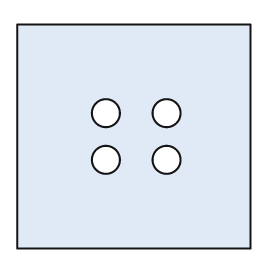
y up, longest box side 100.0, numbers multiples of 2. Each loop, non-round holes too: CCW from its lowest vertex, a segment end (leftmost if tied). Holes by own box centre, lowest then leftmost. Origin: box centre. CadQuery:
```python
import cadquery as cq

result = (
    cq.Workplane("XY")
    .moveTo(-50.0, -48.0)
    .lineTo(50.0, -48.0)
    .lineTo(50.0, 48.0)
    .lineTo(-50.0, 48.0)
    .close()
    .moveTo(-12.0, -10.0)
    .circle(6.0)
    .moveTo(14.0, -10.0)
    .circle(6.0)
    .moveTo(-12.0, 10.0)
    .circle(6.0)
    .moveTo(14.0, 10.0)
    .circle(6.0)
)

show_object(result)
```